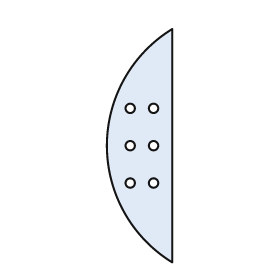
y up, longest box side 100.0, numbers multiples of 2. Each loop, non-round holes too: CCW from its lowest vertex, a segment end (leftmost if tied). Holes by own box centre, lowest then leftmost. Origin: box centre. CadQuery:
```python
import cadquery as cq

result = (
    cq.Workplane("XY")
    .moveTo(14.0, -50.0)
    .lineTo(14.0, 50.0)
    .threePointArc((-14.0, 0.0), (14.0, -50.0))
    .close()
    .moveTo(-4.0, -16.0)
    .circle(2.0)
    .moveTo(6.0, -16.0)
    .circle(2.0)
    .moveTo(-4.0, 0.0)
    .circle(2.0)
    .moveTo(6.0, 0.0)
    .circle(2.0)
    .moveTo(-4.0, 16.0)
    .circle(2.0)
    .moveTo(6.0, 16.0)
    .circle(2.0)
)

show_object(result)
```